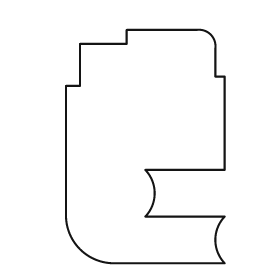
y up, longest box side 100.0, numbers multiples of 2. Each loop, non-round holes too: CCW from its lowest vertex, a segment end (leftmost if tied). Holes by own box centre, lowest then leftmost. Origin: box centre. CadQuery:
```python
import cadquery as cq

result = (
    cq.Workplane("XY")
    .moveTo(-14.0, -50.0)
    .lineTo(34.0, -50.0)
    .threePointArc((30.0, -40.0), (34.0, -30.0))
    .lineTo(0.0, -30.0)
    .threePointArc((4.0, -20.0), (0.0, -10.0))
    .lineTo(34.0, -10.0)
    .lineTo(34.0, 30.0)
    .lineTo(30.0, 30.0)
    .lineTo(30.0, 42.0)
    .threePointArc((28.0, 48.0), (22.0, 50.0))
    .lineTo(-8.0, 50.0)
    .lineTo(-8.0, 44.0)
    .lineTo(-28.0, 44.0)
    .lineTo(-28.0, 26.0)
    .lineTo(-34.0, 26.0)
    .lineTo(-34.0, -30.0)
    .threePointArc((-28.0, -44.0), (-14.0, -50.0))
    .close()
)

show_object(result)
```